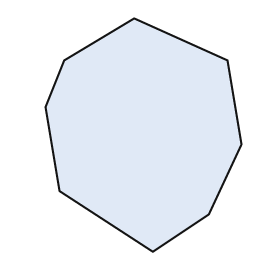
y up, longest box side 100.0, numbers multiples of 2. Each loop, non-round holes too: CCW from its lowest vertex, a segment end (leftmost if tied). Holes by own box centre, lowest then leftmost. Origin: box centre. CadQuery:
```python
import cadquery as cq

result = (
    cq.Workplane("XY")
    .moveTo(4.0, -50.0)
    .lineTo(28.0, -34.0)
    .lineTo(42.0, -4.0)
    .lineTo(36.0, 32.0)
    .lineTo(-4.0, 50.0)
    .lineTo(-34.0, 32.0)
    .lineTo(-42.0, 12.0)
    .lineTo(-36.0, -24.0)
    .close()
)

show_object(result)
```